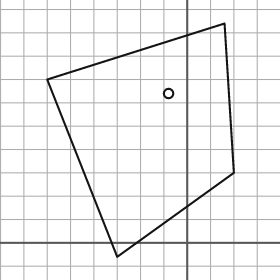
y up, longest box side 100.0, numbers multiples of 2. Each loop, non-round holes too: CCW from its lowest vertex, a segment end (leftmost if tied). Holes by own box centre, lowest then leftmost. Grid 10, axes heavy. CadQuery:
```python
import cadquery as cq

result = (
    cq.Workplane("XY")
    .moveTo(-30.0, -6.0)
    .lineTo(20.0, 30.0)
    .lineTo(16.0, 94.0)
    .lineTo(-60.0, 70.0)
    .close()
    .moveTo(-8.0, 64.0)
    .circle(2.0)
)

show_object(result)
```